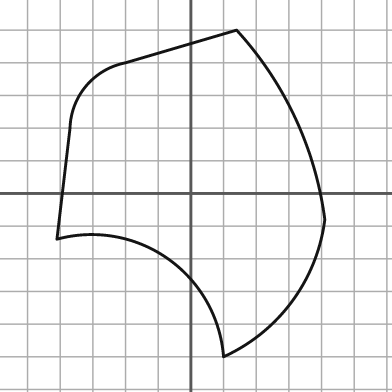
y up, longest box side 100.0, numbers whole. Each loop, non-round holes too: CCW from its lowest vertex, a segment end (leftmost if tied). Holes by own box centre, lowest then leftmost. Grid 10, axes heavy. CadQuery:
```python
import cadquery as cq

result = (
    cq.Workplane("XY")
    .moveTo(10.0, -50.0)
    .threePointArc((31.0, -33.0), (41.0, -8.0))
    .threePointArc((32.0, 23.0), (14.0, 50.0))
    .lineTo(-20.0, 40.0)
    .threePointArc((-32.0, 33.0), (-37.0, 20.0))
    .lineTo(-41.0, -14.0)
    .threePointArc((-7.0, -20.0), (10.0, -50.0))
    .close()
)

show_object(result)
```